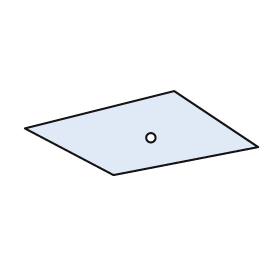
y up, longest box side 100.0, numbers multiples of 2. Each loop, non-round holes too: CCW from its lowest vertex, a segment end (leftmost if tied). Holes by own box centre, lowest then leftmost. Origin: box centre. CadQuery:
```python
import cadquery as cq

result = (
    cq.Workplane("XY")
    .moveTo(-12.0, -18.0)
    .lineTo(50.0, -6.0)
    .lineTo(14.0, 18.0)
    .lineTo(-50.0, 2.0)
    .close()
    .moveTo(4.0, -2.0)
    .circle(2.0)
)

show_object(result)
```